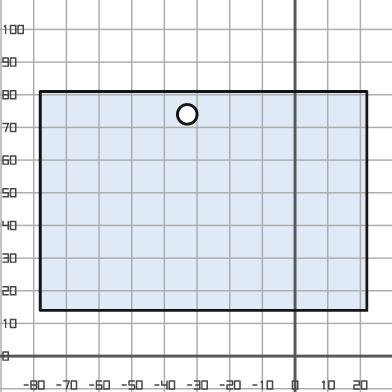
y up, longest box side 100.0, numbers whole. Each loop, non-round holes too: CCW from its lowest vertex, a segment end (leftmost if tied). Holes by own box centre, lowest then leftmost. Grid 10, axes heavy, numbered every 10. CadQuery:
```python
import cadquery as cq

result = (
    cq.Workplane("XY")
    .moveTo(-78.0, 14.0)
    .lineTo(22.0, 14.0)
    .lineTo(22.0, 81.0)
    .lineTo(-78.0, 81.0)
    .close()
    .moveTo(-33.0, 74.0)
    .circle(3.0)
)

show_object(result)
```